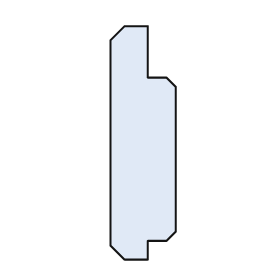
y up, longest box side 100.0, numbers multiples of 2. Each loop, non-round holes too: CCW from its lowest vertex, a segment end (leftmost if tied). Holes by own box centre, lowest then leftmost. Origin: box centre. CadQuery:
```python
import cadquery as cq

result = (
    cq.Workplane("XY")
    .moveTo(-8.0, -50.0)
    .lineTo(2.0, -50.0)
    .lineTo(2.0, -42.0)
    .lineTo(10.0, -42.0)
    .lineTo(14.0, -38.0)
    .lineTo(14.0, 24.0)
    .lineTo(10.0, 28.0)
    .lineTo(2.0, 28.0)
    .lineTo(2.0, 50.0)
    .lineTo(-8.0, 50.0)
    .lineTo(-14.0, 44.0)
    .lineTo(-14.0, -44.0)
    .close()
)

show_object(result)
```